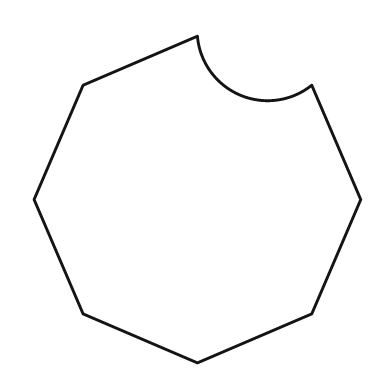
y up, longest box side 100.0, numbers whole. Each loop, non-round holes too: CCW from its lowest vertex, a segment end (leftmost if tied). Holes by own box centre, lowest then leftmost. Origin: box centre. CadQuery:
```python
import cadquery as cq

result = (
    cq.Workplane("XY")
    .moveTo(0.0, -50.0)
    .lineTo(35.0, -35.0)
    .lineTo(50.0, 0.0)
    .lineTo(35.0, 35.0)
    .threePointArc((13.0, 32.0), (0.0, 50.0))
    .lineTo(-35.0, 35.0)
    .lineTo(-50.0, 0.0)
    .lineTo(-35.0, -35.0)
    .close()
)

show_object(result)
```